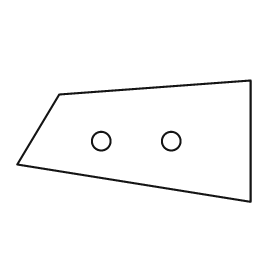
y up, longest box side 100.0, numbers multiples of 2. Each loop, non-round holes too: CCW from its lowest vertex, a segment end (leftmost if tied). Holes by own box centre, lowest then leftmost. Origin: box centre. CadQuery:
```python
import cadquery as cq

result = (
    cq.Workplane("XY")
    .moveTo(50.0, -26.0)
    .lineTo(50.0, 26.0)
    .lineTo(-32.0, 20.0)
    .lineTo(-50.0, -10.0)
    .close()
    .moveTo(-14.0, 0.0)
    .circle(4.0)
    .moveTo(16.0, 0.0)
    .circle(4.0)
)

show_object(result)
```